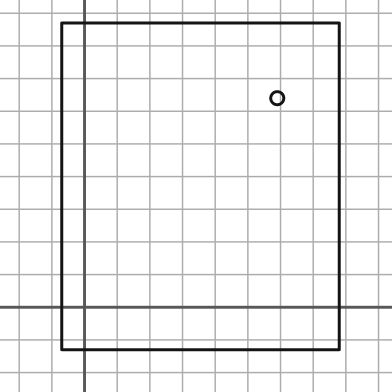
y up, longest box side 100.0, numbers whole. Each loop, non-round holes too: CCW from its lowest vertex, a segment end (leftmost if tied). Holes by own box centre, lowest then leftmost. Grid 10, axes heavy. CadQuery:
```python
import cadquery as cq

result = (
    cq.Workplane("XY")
    .moveTo(-7.0, -13.0)
    .lineTo(78.0, -13.0)
    .lineTo(78.0, 87.0)
    .lineTo(-7.0, 87.0)
    .close()
    .moveTo(59.0, 64.0)
    .circle(2.0)
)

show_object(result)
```